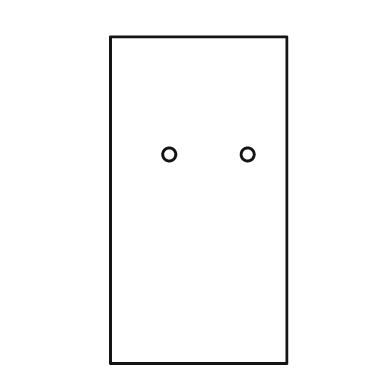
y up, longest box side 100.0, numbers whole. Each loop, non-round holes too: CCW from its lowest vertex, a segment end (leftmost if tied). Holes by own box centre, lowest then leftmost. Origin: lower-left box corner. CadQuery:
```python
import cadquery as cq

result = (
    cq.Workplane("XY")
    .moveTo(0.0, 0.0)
    .lineTo(54.0, 0.0)
    .lineTo(54.0, 100.0)
    .lineTo(0.0, 100.0)
    .close()
    .moveTo(18.0, 64.0)
    .circle(2.0)
    .moveTo(42.0, 64.0)
    .circle(2.0)
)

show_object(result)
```